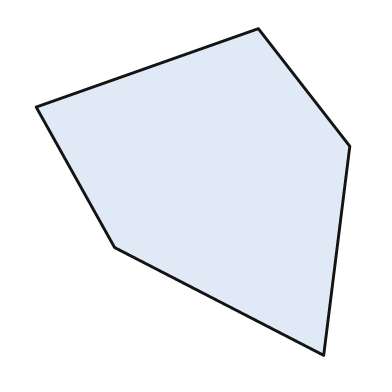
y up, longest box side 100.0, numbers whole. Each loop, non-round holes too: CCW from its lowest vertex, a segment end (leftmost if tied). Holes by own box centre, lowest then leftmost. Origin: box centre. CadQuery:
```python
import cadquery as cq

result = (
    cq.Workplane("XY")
    .moveTo(40.0, -50.0)
    .lineTo(48.0, 14.0)
    .lineTo(20.0, 50.0)
    .lineTo(-48.0, 26.0)
    .lineTo(-24.0, -17.0)
    .close()
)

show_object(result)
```